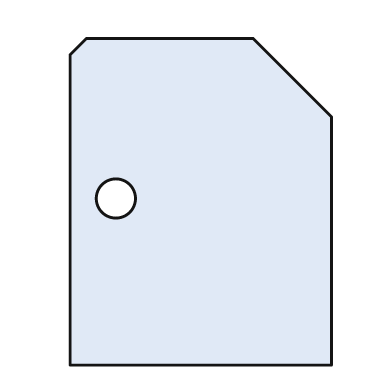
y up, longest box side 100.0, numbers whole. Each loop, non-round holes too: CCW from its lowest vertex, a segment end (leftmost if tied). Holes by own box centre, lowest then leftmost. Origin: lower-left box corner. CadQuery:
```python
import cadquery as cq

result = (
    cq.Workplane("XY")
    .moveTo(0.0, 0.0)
    .lineTo(80.0, 0.0)
    .lineTo(80.0, 76.0)
    .lineTo(56.0, 100.0)
    .lineTo(5.0, 100.0)
    .lineTo(0.0, 95.0)
    .close()
    .moveTo(14.0, 51.0)
    .circle(6.0)
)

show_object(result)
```